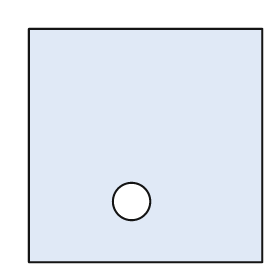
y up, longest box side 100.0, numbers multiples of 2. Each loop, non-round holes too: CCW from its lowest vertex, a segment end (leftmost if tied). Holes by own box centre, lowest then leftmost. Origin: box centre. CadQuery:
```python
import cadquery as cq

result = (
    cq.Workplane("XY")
    .moveTo(-50.0, -50.0)
    .lineTo(50.0, -50.0)
    .lineTo(50.0, 50.0)
    .lineTo(-50.0, 50.0)
    .close()
    .moveTo(-6.0, -24.0)
    .circle(8.0)
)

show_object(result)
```